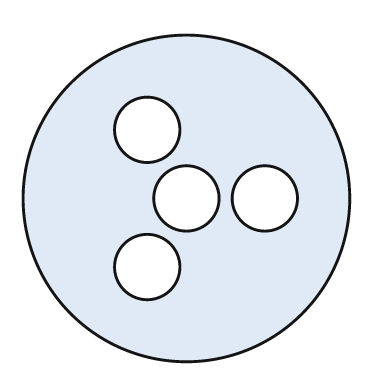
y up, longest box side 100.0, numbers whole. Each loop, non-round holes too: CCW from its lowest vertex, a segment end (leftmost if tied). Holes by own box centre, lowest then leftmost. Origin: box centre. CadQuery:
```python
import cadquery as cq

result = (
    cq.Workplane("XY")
    .moveTo(0.0, 0.0)
    .circle(50.0)
    .moveTo(-12.0, -21.0)
    .circle(10.0)
    .moveTo(0.0, 0.0)
    .circle(10.0)
    .moveTo(24.0, 0.0)
    .circle(10.0)
    .moveTo(-12.0, 21.0)
    .circle(10.0)
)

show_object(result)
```